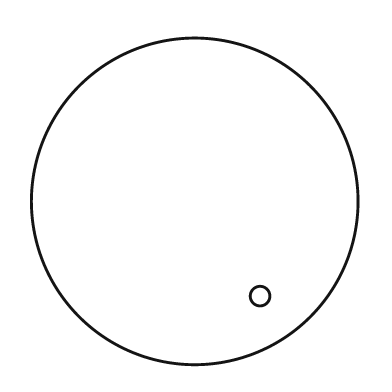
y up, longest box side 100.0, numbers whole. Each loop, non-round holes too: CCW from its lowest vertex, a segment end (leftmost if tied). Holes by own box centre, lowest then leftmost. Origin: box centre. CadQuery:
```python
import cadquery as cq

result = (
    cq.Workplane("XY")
    .moveTo(0.0, 0.0)
    .circle(50.0)
    .moveTo(20.0, -29.0)
    .circle(3.0)
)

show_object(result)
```